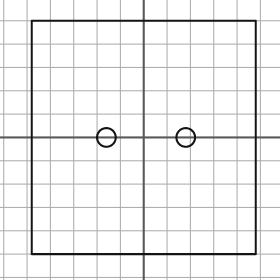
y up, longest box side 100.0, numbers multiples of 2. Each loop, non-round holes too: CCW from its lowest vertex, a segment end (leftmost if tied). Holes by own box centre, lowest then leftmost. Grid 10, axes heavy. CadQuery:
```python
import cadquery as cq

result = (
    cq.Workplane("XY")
    .moveTo(-48.0, -50.0)
    .lineTo(48.0, -50.0)
    .lineTo(48.0, 50.0)
    .lineTo(-48.0, 50.0)
    .close()
    .moveTo(-16.0, 0.0)
    .circle(4.0)
    .moveTo(18.0, 0.0)
    .circle(4.0)
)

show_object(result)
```